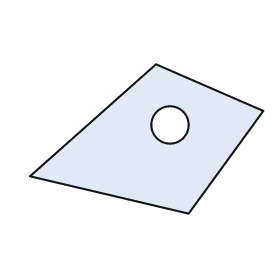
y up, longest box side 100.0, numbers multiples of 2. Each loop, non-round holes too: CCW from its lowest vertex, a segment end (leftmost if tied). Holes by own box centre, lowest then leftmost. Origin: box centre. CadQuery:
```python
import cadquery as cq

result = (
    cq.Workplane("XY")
    .moveTo(18.0, -32.0)
    .lineTo(50.0, 12.0)
    .lineTo(4.0, 32.0)
    .lineTo(-50.0, -16.0)
    .close()
    .moveTo(10.0, 6.0)
    .circle(8.0)
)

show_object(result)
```